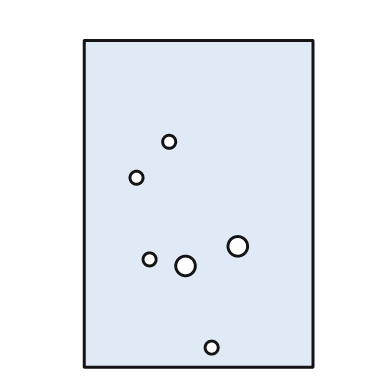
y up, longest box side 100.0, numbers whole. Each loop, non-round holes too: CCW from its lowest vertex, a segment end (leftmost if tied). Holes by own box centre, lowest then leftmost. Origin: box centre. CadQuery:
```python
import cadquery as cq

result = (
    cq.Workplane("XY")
    .moveTo(-35.0, -50.0)
    .lineTo(35.0, -50.0)
    .lineTo(35.0, 50.0)
    .lineTo(-35.0, 50.0)
    .close()
    .moveTo(4.0, -44.0)
    .circle(2.0)
    .moveTo(-4.0, -19.0)
    .circle(3.0)
    .moveTo(-15.0, -17.0)
    .circle(2.0)
    .moveTo(12.0, -13.0)
    .circle(3.0)
    .moveTo(-19.0, 8.0)
    .circle(2.0)
    .moveTo(-9.0, 19.0)
    .circle(2.0)
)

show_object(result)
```